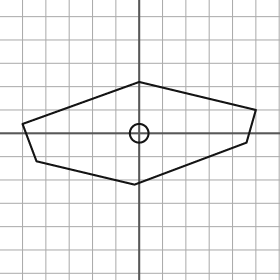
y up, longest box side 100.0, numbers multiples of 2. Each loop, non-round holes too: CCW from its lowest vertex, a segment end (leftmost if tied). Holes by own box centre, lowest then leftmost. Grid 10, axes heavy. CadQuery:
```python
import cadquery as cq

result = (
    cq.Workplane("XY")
    .moveTo(-2.0, -22.0)
    .lineTo(46.0, -4.0)
    .lineTo(50.0, 10.0)
    .lineTo(0.0, 22.0)
    .lineTo(-50.0, 4.0)
    .lineTo(-44.0, -12.0)
    .close()
    .moveTo(0.0, 0.0)
    .circle(4.0)
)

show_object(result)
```